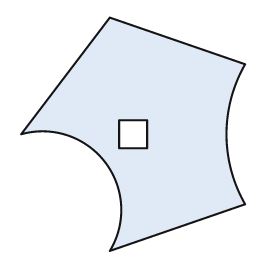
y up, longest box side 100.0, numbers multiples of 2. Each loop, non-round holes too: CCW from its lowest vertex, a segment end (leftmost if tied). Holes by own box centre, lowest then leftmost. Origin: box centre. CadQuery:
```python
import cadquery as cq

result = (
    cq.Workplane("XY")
    .moveTo(-10.0, -50.0)
    .lineTo(48.0, -30.0)
    .threePointArc((40.0, 0.0), (48.0, 30.0))
    .lineTo(-10.0, 50.0)
    .lineTo(-48.0, 0.0)
    .threePointArc((-12.0, -12.0), (-10.0, -50.0))
    .close()
    .moveTo(-6.0, -6.0)
    .lineTo(6.0, -6.0)
    .lineTo(6.0, 6.0)
    .lineTo(-6.0, 6.0)
    .close()
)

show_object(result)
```